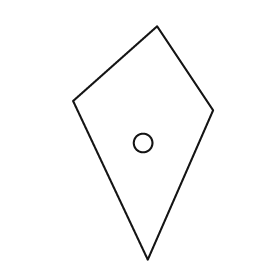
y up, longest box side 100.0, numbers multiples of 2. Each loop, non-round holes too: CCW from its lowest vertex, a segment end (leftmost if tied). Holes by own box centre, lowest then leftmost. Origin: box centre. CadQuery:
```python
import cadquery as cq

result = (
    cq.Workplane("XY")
    .moveTo(2.0, -50.0)
    .lineTo(30.0, 14.0)
    .lineTo(6.0, 50.0)
    .lineTo(-30.0, 18.0)
    .close()
    .moveTo(0.0, 0.0)
    .circle(4.0)
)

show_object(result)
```